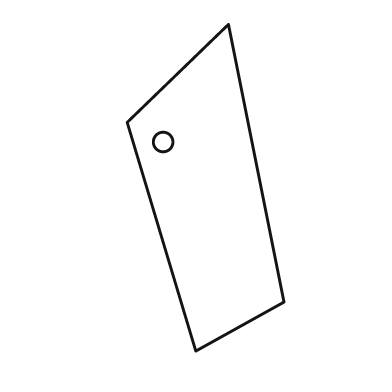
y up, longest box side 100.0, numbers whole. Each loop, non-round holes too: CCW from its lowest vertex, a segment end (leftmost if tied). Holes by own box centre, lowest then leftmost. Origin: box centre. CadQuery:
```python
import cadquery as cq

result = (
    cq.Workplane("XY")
    .moveTo(-3.0, -50.0)
    .lineTo(24.0, -35.0)
    .lineTo(7.0, 50.0)
    .lineTo(-24.0, 20.0)
    .close()
    .moveTo(-13.0, 14.0)
    .circle(3.0)
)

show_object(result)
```